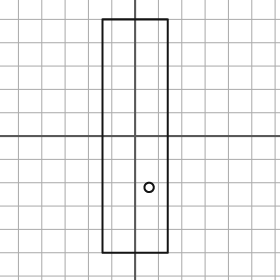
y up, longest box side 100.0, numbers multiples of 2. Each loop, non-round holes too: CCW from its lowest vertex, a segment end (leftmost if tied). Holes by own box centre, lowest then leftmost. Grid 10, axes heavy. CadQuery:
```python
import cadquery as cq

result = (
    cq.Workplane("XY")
    .moveTo(-14.0, -50.0)
    .lineTo(14.0, -50.0)
    .lineTo(14.0, 50.0)
    .lineTo(-14.0, 50.0)
    .close()
    .moveTo(6.0, -22.0)
    .circle(2.0)
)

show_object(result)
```